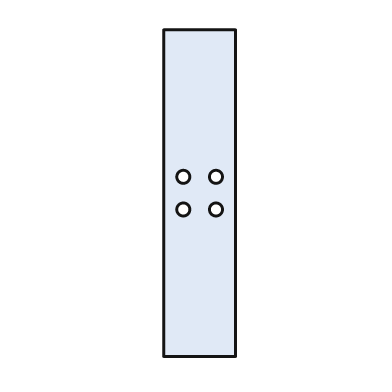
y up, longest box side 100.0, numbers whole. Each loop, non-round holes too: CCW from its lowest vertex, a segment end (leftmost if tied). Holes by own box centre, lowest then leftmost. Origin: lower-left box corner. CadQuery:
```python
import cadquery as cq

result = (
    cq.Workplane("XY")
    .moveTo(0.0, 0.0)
    .lineTo(22.0, 0.0)
    .lineTo(22.0, 100.0)
    .lineTo(0.0, 100.0)
    .close()
    .moveTo(6.0, 45.0)
    .circle(2.0)
    .moveTo(16.0, 45.0)
    .circle(2.0)
    .moveTo(6.0, 55.0)
    .circle(2.0)
    .moveTo(16.0, 55.0)
    .circle(2.0)
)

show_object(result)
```